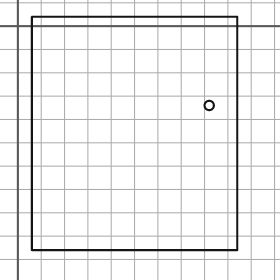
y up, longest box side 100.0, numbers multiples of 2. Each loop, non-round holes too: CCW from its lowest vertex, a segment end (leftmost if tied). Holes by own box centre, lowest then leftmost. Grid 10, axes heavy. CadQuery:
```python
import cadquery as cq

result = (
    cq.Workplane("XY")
    .moveTo(6.0, -96.0)
    .lineTo(94.0, -96.0)
    .lineTo(94.0, 4.0)
    .lineTo(6.0, 4.0)
    .close()
    .moveTo(82.0, -34.0)
    .circle(2.0)
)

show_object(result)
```